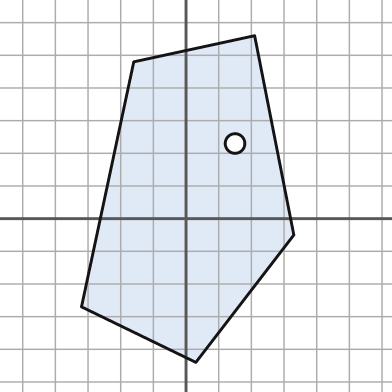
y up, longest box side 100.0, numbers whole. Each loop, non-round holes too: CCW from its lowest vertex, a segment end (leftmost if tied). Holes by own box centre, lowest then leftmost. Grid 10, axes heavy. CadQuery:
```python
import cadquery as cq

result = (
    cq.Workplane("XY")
    .moveTo(3.0, -44.0)
    .lineTo(33.0, -5.0)
    .lineTo(21.0, 56.0)
    .lineTo(-16.0, 48.0)
    .lineTo(-32.0, -27.0)
    .close()
    .moveTo(15.0, 23.0)
    .circle(3.0)
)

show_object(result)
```